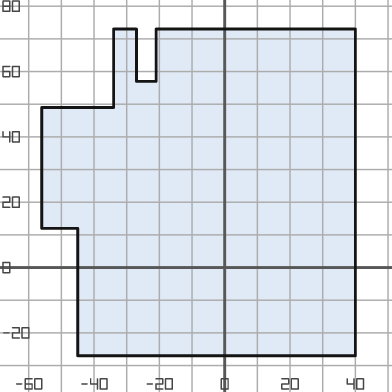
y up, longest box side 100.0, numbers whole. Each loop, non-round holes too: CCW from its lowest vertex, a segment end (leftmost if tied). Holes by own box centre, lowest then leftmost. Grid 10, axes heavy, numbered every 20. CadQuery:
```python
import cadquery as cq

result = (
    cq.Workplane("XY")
    .moveTo(-45.0, -27.0)
    .lineTo(40.0, -27.0)
    .lineTo(40.0, 73.0)
    .lineTo(-21.0, 73.0)
    .lineTo(-21.0, 57.0)
    .lineTo(-27.0, 57.0)
    .lineTo(-27.0, 73.0)
    .lineTo(-34.0, 73.0)
    .lineTo(-34.0, 49.0)
    .lineTo(-56.0, 49.0)
    .lineTo(-56.0, 12.0)
    .lineTo(-45.0, 12.0)
    .close()
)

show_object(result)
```